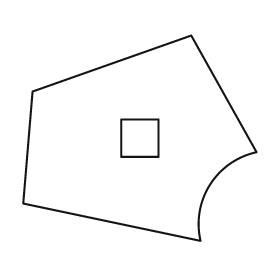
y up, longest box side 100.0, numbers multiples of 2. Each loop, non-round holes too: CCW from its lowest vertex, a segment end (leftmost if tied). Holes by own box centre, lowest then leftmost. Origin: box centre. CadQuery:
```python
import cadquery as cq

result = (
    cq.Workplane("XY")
    .moveTo(26.0, -44.0)
    .threePointArc((30.0, -20.0), (50.0, -6.0))
    .lineTo(22.0, 44.0)
    .lineTo(-46.0, 20.0)
    .lineTo(-50.0, -28.0)
    .close()
    .moveTo(-8.0, -8.0)
    .lineTo(8.0, -8.0)
    .lineTo(8.0, 8.0)
    .lineTo(-8.0, 8.0)
    .close()
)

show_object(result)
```